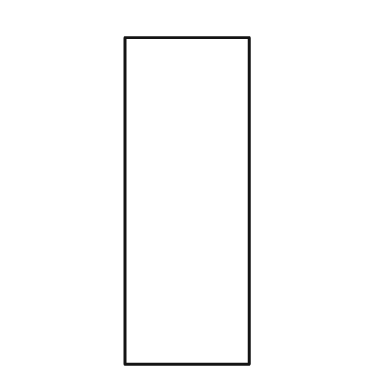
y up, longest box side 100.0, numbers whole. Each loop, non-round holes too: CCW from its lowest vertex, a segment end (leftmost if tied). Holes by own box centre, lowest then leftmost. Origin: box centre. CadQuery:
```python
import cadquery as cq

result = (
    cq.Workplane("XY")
    .moveTo(-19.0, -50.0)
    .lineTo(19.0, -50.0)
    .lineTo(19.0, 50.0)
    .lineTo(-19.0, 50.0)
    .close()
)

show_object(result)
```